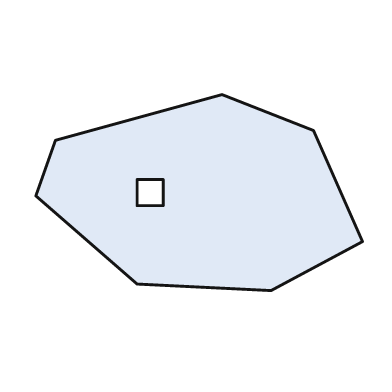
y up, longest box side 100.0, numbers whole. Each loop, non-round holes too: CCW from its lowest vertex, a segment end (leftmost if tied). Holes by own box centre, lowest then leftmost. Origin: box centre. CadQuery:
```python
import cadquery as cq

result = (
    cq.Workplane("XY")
    .moveTo(22.0, -30.0)
    .lineTo(50.0, -15.0)
    .lineTo(35.0, 19.0)
    .lineTo(7.0, 30.0)
    .lineTo(-44.0, 16.0)
    .lineTo(-50.0, -1.0)
    .lineTo(-19.0, -28.0)
    .close()
    .moveTo(-19.0, -4.0)
    .lineTo(-11.0, -4.0)
    .lineTo(-11.0, 4.0)
    .lineTo(-19.0, 4.0)
    .close()
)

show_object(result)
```